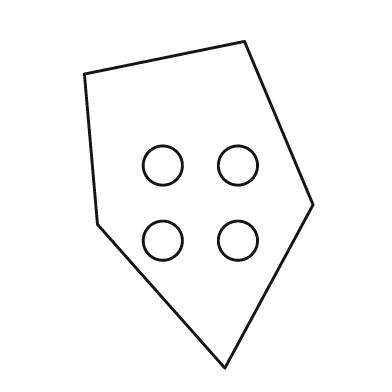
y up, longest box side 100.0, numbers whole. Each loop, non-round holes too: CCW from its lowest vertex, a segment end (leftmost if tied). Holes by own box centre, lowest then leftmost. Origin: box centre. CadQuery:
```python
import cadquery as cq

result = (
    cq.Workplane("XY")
    .moveTo(8.0, -50.0)
    .lineTo(35.0, 0.0)
    .lineTo(14.0, 50.0)
    .lineTo(-35.0, 40.0)
    .lineTo(-31.0, -6.0)
    .close()
    .moveTo(-11.0, -11.0)
    .circle(6.0)
    .moveTo(12.0, -11.0)
    .circle(6.0)
    .moveTo(-11.0, 12.0)
    .circle(6.0)
    .moveTo(12.0, 12.0)
    .circle(6.0)
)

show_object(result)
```